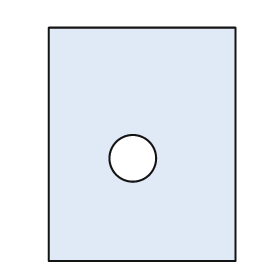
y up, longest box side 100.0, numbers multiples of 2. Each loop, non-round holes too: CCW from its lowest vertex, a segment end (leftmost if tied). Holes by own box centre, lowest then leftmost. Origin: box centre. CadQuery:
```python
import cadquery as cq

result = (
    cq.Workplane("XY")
    .moveTo(-40.0, -50.0)
    .lineTo(40.0, -50.0)
    .lineTo(40.0, 50.0)
    .lineTo(-40.0, 50.0)
    .close()
    .moveTo(-4.0, -6.0)
    .circle(10.0)
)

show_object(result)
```